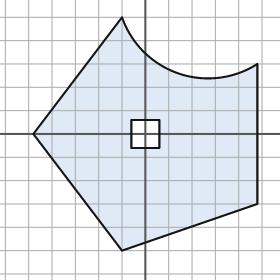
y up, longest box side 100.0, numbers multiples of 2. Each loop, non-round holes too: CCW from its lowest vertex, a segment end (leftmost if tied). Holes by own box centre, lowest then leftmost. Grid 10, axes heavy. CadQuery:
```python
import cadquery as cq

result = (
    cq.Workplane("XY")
    .moveTo(-10.0, -50.0)
    .lineTo(48.0, -30.0)
    .lineTo(48.0, 30.0)
    .threePointArc((14.0, 26.0), (-10.0, 50.0))
    .lineTo(-48.0, 0.0)
    .close()
    .moveTo(-6.0, -6.0)
    .lineTo(6.0, -6.0)
    .lineTo(6.0, 6.0)
    .lineTo(-6.0, 6.0)
    .close()
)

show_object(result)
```